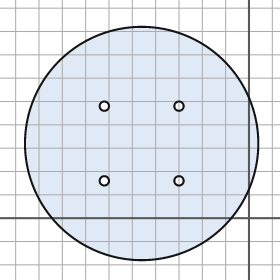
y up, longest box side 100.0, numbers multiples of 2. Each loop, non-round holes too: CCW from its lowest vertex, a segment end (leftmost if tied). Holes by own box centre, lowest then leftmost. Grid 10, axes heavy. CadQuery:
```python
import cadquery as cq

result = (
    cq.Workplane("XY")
    .moveTo(-46.0, 32.0)
    .circle(50.0)
    .moveTo(-62.0, 16.0)
    .circle(2.0)
    .moveTo(-30.0, 16.0)
    .circle(2.0)
    .moveTo(-62.0, 48.0)
    .circle(2.0)
    .moveTo(-30.0, 48.0)
    .circle(2.0)
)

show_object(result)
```